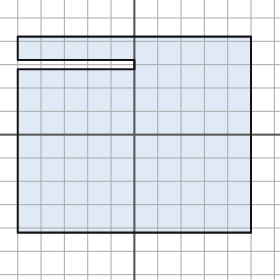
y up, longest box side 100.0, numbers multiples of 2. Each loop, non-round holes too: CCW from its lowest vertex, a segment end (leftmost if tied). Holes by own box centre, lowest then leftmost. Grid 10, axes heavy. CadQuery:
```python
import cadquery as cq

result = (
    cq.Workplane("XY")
    .moveTo(-50.0, -42.0)
    .lineTo(50.0, -42.0)
    .lineTo(50.0, 42.0)
    .lineTo(-50.0, 42.0)
    .lineTo(-50.0, 32.0)
    .lineTo(0.0, 32.0)
    .lineTo(0.0, 28.0)
    .lineTo(-50.0, 28.0)
    .close()
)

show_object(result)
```